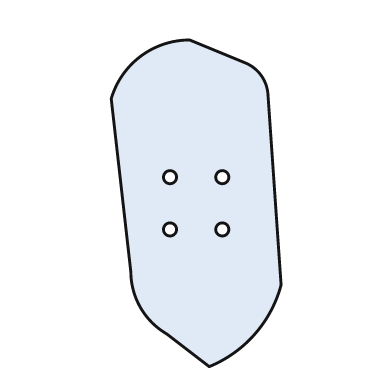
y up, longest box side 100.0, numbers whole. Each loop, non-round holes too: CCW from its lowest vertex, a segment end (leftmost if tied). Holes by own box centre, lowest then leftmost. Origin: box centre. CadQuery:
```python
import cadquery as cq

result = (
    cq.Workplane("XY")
    .moveTo(4.0, -50.0)
    .threePointArc((18.0, -40.0), (26.0, -25.0))
    .lineTo(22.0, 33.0)
    .threePointArc((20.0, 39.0), (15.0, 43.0))
    .lineTo(-2.0, 50.0)
    .threePointArc((-17.0, 45.0), (-26.0, 32.0))
    .lineTo(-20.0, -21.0)
    .threePointArc((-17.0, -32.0), (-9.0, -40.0))
    .close()
    .moveTo(-8.0, -8.0)
    .circle(2.0)
    .moveTo(8.0, -8.0)
    .circle(2.0)
    .moveTo(-8.0, 8.0)
    .circle(2.0)
    .moveTo(8.0, 8.0)
    .circle(2.0)
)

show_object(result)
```